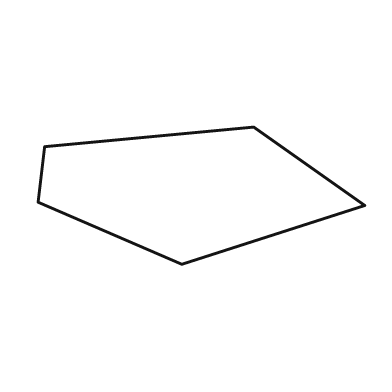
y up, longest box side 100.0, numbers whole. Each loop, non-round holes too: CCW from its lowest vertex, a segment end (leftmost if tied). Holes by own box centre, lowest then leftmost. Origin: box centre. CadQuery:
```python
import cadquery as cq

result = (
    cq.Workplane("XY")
    .moveTo(-6.0, -21.0)
    .lineTo(50.0, -3.0)
    .lineTo(16.0, 21.0)
    .lineTo(-48.0, 15.0)
    .lineTo(-50.0, -2.0)
    .close()
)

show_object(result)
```